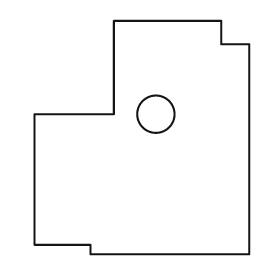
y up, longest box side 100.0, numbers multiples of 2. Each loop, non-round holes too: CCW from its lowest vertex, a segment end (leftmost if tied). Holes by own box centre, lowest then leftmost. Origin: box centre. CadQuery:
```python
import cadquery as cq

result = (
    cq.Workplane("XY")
    .moveTo(-22.0, -50.0)
    .lineTo(46.0, -50.0)
    .lineTo(46.0, 40.0)
    .lineTo(34.0, 40.0)
    .lineTo(34.0, 50.0)
    .lineTo(-12.0, 50.0)
    .lineTo(-12.0, 10.0)
    .lineTo(-46.0, 10.0)
    .lineTo(-46.0, -46.0)
    .lineTo(-22.0, -46.0)
    .close()
    .moveTo(6.0, 10.0)
    .circle(8.0)
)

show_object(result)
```